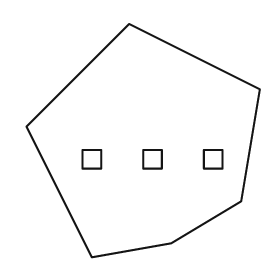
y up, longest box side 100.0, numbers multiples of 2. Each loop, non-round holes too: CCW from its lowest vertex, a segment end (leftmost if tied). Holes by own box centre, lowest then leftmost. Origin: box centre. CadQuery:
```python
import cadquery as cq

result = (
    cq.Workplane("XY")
    .moveTo(-22.0, -50.0)
    .lineTo(12.0, -44.0)
    .lineTo(42.0, -26.0)
    .lineTo(50.0, 22.0)
    .lineTo(-6.0, 50.0)
    .lineTo(-50.0, 6.0)
    .close()
    .moveTo(-26.0, -12.0)
    .lineTo(-18.0, -12.0)
    .lineTo(-18.0, -4.0)
    .lineTo(-26.0, -4.0)
    .close()
    .moveTo(0.0, -12.0)
    .lineTo(8.0, -12.0)
    .lineTo(8.0, -4.0)
    .lineTo(0.0, -4.0)
    .close()
    .moveTo(26.0, -12.0)
    .lineTo(34.0, -12.0)
    .lineTo(34.0, -4.0)
    .lineTo(26.0, -4.0)
    .close()
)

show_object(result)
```